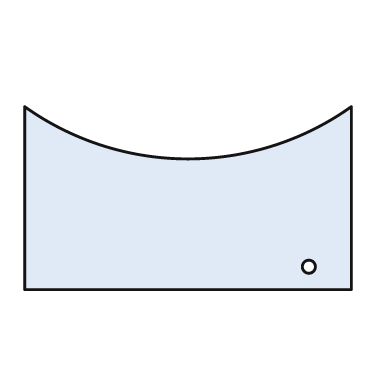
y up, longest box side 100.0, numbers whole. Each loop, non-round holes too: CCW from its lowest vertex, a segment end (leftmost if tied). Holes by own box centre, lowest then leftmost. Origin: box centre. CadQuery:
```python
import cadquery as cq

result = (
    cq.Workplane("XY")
    .moveTo(-50.0, -28.0)
    .lineTo(50.0, -28.0)
    .lineTo(50.0, 28.0)
    .threePointArc((0.0, 12.0), (-50.0, 28.0))
    .close()
    .moveTo(37.0, -21.0)
    .circle(2.0)
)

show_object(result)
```